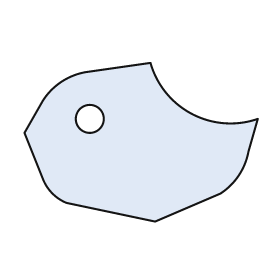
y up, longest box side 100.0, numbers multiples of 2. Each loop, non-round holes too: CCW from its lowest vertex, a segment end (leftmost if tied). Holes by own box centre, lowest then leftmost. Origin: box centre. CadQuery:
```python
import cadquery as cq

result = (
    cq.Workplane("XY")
    .moveTo(6.0, -34.0)
    .lineTo(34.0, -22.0)
    .threePointArc((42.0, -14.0), (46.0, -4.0))
    .lineTo(50.0, 10.0)
    .threePointArc((22.0, 12.0), (4.0, 34.0))
    .lineTo(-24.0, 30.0)
    .threePointArc((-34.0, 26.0), (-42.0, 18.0))
    .lineTo(-50.0, 4.0)
    .lineTo(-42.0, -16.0)
    .threePointArc((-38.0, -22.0), (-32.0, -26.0))
    .close()
    .moveTo(-22.0, 10.0)
    .circle(6.0)
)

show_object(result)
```